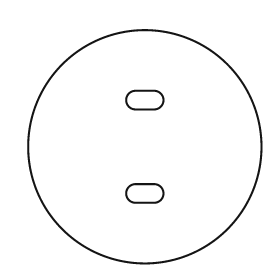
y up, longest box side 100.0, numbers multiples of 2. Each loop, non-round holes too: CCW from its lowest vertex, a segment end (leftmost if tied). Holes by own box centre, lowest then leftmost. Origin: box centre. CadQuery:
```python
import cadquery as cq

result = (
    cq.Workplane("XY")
    .moveTo(0.0, 0.0)
    .circle(50.0)
    .moveTo(-4.0, -24.0)
    .lineTo(4.0, -24.0)
    .threePointArc((8.0, -20.0), (4.0, -16.0))
    .lineTo(-4.0, -16.0)
    .threePointArc((-8.0, -20.0), (-4.0, -24.0))
    .close()
    .moveTo(-4.0, 16.0)
    .lineTo(4.0, 16.0)
    .threePointArc((8.0, 20.0), (4.0, 24.0))
    .lineTo(-4.0, 24.0)
    .threePointArc((-8.0, 20.0), (-4.0, 16.0))
    .close()
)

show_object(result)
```